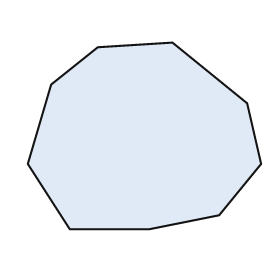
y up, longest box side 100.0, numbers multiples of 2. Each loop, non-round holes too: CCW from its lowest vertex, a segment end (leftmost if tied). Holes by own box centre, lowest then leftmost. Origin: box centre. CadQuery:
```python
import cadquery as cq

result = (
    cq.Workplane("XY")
    .moveTo(-32.0, -40.0)
    .lineTo(2.0, -40.0)
    .lineTo(32.0, -34.0)
    .lineTo(50.0, -12.0)
    .lineTo(44.0, 14.0)
    .lineTo(12.0, 40.0)
    .lineTo(-20.0, 38.0)
    .lineTo(-40.0, 22.0)
    .lineTo(-50.0, -12.0)
    .close()
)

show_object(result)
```